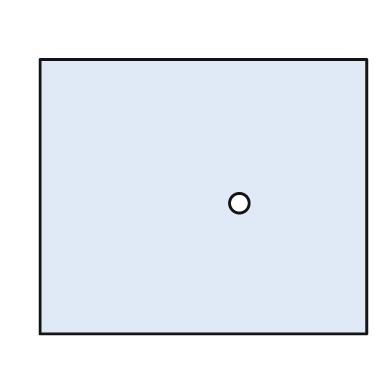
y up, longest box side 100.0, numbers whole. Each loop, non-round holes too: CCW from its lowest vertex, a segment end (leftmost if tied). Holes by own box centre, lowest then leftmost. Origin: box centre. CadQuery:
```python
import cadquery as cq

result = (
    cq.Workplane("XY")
    .moveTo(-50.0, -42.0)
    .lineTo(50.0, -42.0)
    .lineTo(50.0, 42.0)
    .lineTo(-50.0, 42.0)
    .close()
    .moveTo(11.0, -2.0)
    .circle(3.0)
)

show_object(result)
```